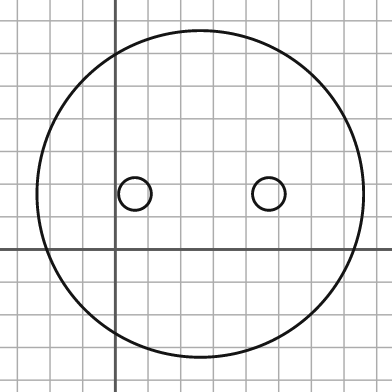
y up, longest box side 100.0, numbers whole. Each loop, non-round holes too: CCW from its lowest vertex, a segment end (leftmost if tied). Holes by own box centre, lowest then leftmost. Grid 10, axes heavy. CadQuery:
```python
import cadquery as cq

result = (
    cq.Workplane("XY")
    .moveTo(26.0, 17.0)
    .circle(50.0)
    .moveTo(6.0, 17.0)
    .circle(5.0)
    .moveTo(47.0, 17.0)
    .circle(5.0)
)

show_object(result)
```